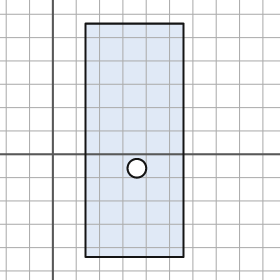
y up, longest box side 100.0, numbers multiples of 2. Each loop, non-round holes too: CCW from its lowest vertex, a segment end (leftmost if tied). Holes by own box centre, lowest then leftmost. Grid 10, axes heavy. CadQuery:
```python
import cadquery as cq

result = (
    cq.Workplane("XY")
    .moveTo(14.0, -44.0)
    .lineTo(56.0, -44.0)
    .lineTo(56.0, 56.0)
    .lineTo(14.0, 56.0)
    .close()
    .moveTo(36.0, -6.0)
    .circle(4.0)
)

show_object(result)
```